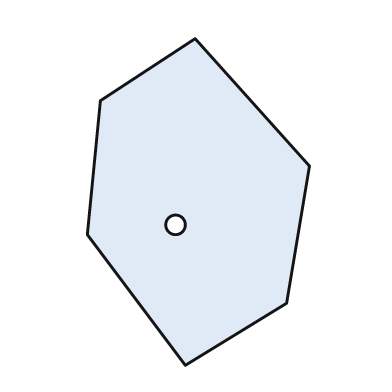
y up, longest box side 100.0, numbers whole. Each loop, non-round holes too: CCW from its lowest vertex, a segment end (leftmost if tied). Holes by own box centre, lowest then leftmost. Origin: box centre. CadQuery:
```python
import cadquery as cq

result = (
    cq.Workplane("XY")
    .moveTo(-4.0, -50.0)
    .lineTo(27.0, -31.0)
    .lineTo(34.0, 11.0)
    .lineTo(-1.0, 50.0)
    .lineTo(-30.0, 31.0)
    .lineTo(-34.0, -10.0)
    .close()
    .moveTo(-7.0, -7.0)
    .circle(3.0)
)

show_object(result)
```